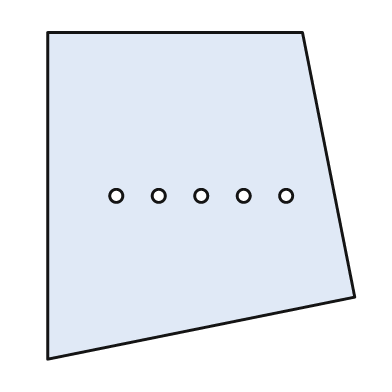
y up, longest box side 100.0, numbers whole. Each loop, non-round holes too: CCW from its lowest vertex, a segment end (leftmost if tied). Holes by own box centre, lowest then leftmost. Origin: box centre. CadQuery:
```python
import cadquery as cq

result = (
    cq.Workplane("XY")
    .moveTo(-47.0, -50.0)
    .lineTo(47.0, -31.0)
    .lineTo(31.0, 50.0)
    .lineTo(-47.0, 50.0)
    .close()
    .moveTo(-26.0, 0.0)
    .circle(2.0)
    .moveTo(-13.0, 0.0)
    .circle(2.0)
    .moveTo(0.0, 0.0)
    .circle(2.0)
    .moveTo(13.0, 0.0)
    .circle(2.0)
    .moveTo(26.0, 0.0)
    .circle(2.0)
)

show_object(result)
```